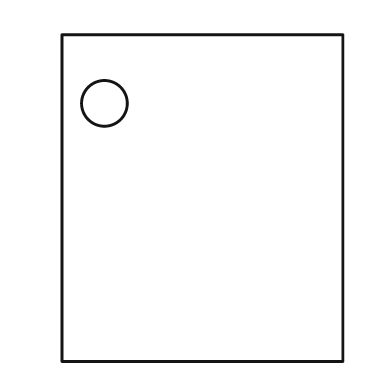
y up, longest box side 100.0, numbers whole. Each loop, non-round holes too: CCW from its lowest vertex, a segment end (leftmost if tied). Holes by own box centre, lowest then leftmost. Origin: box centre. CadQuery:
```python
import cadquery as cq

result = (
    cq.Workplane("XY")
    .moveTo(-43.0, -50.0)
    .lineTo(43.0, -50.0)
    .lineTo(43.0, 50.0)
    .lineTo(-43.0, 50.0)
    .close()
    .moveTo(-30.0, 29.0)
    .circle(7.0)
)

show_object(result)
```